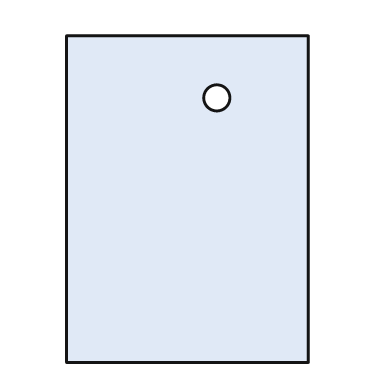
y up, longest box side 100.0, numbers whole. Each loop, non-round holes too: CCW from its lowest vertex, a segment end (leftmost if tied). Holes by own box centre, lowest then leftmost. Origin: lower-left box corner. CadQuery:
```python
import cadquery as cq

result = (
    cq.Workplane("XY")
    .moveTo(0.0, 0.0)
    .lineTo(74.0, 0.0)
    .lineTo(74.0, 100.0)
    .lineTo(0.0, 100.0)
    .close()
    .moveTo(46.0, 81.0)
    .circle(4.0)
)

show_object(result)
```